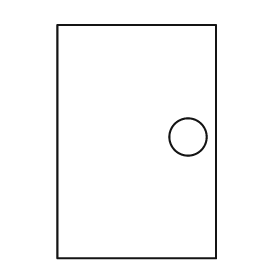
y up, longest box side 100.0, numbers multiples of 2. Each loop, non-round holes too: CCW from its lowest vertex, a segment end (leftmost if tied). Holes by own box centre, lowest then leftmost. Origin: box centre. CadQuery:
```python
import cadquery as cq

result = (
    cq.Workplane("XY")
    .moveTo(-34.0, -50.0)
    .lineTo(34.0, -50.0)
    .lineTo(34.0, 50.0)
    .lineTo(-34.0, 50.0)
    .close()
    .moveTo(22.0, 2.0)
    .circle(8.0)
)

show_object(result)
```